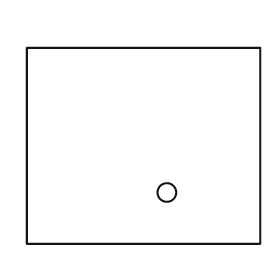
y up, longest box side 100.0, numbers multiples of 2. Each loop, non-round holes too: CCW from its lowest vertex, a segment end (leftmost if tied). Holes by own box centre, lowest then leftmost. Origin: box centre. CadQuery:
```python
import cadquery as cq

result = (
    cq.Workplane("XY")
    .moveTo(-50.0, -42.0)
    .lineTo(50.0, -42.0)
    .lineTo(50.0, 42.0)
    .lineTo(-50.0, 42.0)
    .close()
    .moveTo(10.0, -20.0)
    .circle(4.0)
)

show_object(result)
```